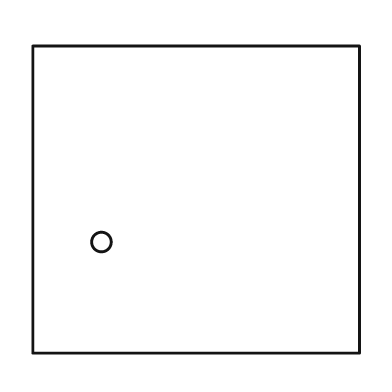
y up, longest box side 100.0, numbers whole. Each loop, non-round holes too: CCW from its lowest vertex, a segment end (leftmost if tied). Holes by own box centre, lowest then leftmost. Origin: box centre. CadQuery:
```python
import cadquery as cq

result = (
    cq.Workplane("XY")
    .moveTo(-50.0, -47.0)
    .lineTo(50.0, -47.0)
    .lineTo(50.0, 47.0)
    .lineTo(-50.0, 47.0)
    .close()
    .moveTo(-29.0, -13.0)
    .circle(3.0)
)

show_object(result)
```